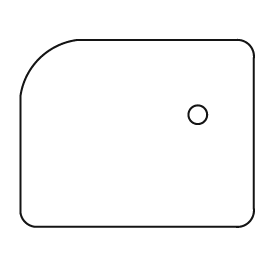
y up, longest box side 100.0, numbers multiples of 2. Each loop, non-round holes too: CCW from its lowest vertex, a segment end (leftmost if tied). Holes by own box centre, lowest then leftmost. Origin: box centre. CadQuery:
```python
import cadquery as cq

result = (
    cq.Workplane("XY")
    .moveTo(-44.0, -40.0)
    .lineTo(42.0, -40.0)
    .threePointArc((48.0, -38.0), (50.0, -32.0))
    .lineTo(50.0, 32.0)
    .threePointArc((48.0, 38.0), (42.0, 40.0))
    .lineTo(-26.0, 40.0)
    .threePointArc((-42.0, 32.0), (-50.0, 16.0))
    .lineTo(-50.0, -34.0)
    .threePointArc((-48.0, -38.0), (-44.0, -40.0))
    .close()
    .moveTo(26.0, 8.0)
    .circle(4.0)
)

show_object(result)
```